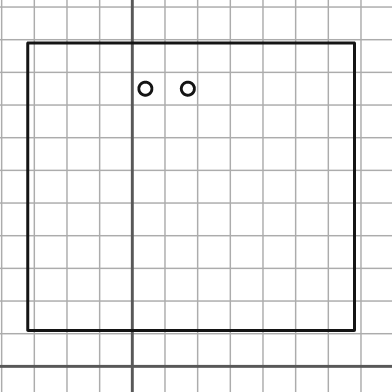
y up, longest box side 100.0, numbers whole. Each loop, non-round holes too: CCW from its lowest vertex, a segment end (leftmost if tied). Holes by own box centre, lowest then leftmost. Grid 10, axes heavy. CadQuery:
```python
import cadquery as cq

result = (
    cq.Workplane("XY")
    .moveTo(-32.0, 11.0)
    .lineTo(68.0, 11.0)
    .lineTo(68.0, 99.0)
    .lineTo(-32.0, 99.0)
    .close()
    .moveTo(4.0, 85.0)
    .circle(2.0)
    .moveTo(17.0, 85.0)
    .circle(2.0)
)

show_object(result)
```